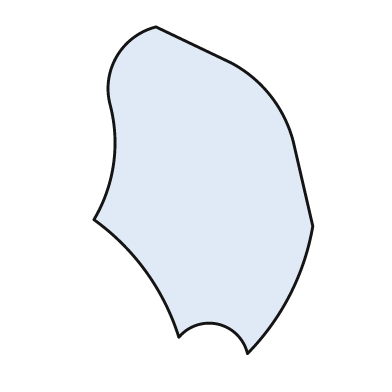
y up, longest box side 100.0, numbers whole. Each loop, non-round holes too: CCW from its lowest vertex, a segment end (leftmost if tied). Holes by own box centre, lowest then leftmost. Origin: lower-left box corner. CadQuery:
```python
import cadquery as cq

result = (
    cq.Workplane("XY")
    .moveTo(47.0, 0.0)
    .threePointArc((60.0, 18.0), (67.0, 39.0))
    .lineTo(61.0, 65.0)
    .threePointArc((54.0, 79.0), (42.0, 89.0))
    .lineTo(19.0, 100.0)
    .threePointArc((7.0, 91.0), (5.0, 76.0))
    .threePointArc((6.0, 58.0), (0.0, 41.0))
    .threePointArc((16.0, 25.0), (26.0, 5.0))
    .threePointArc((38.0, 9.0), (47.0, 0.0))
    .close()
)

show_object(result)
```